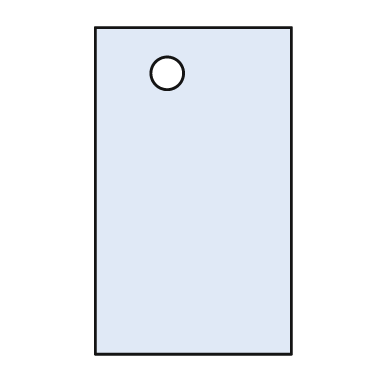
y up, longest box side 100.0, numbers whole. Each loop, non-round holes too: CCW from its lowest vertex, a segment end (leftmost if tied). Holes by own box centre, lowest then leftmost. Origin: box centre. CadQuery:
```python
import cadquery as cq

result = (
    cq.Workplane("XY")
    .moveTo(-30.0, -50.0)
    .lineTo(30.0, -50.0)
    .lineTo(30.0, 50.0)
    .lineTo(-30.0, 50.0)
    .close()
    .moveTo(-8.0, 36.0)
    .circle(5.0)
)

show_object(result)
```